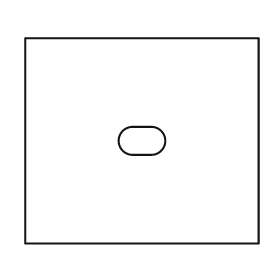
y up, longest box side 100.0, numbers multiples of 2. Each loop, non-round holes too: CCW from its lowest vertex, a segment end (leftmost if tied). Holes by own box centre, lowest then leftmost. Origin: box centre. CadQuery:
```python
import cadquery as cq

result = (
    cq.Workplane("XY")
    .moveTo(-50.0, -44.0)
    .lineTo(50.0, -44.0)
    .lineTo(50.0, 44.0)
    .lineTo(-50.0, 44.0)
    .close()
    .moveTo(-4.0, -6.0)
    .lineTo(4.0, -6.0)
    .threePointArc((10.0, 0.0), (4.0, 6.0))
    .lineTo(-4.0, 6.0)
    .threePointArc((-10.0, 0.0), (-4.0, -6.0))
    .close()
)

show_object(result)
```